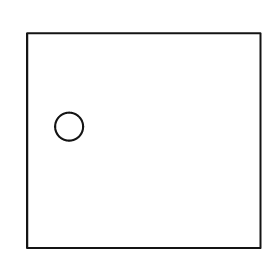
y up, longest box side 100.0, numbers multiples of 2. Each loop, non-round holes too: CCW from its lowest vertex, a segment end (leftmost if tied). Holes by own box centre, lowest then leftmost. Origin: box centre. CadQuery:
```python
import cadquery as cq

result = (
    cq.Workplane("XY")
    .moveTo(-50.0, -46.0)
    .lineTo(50.0, -46.0)
    .lineTo(50.0, 46.0)
    .lineTo(-50.0, 46.0)
    .close()
    .moveTo(-32.0, 6.0)
    .circle(6.0)
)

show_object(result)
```